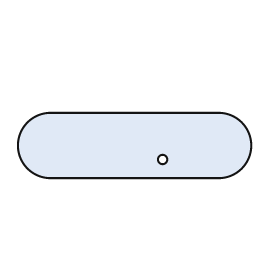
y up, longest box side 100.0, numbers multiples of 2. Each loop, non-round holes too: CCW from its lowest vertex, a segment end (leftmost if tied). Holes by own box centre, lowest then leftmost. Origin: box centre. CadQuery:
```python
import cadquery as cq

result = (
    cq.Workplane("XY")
    .moveTo(-36.0, -14.0)
    .lineTo(36.0, -14.0)
    .threePointArc((50.0, 0.0), (36.0, 14.0))
    .lineTo(-36.0, 14.0)
    .threePointArc((-50.0, 0.0), (-36.0, -14.0))
    .close()
    .moveTo(12.0, -6.0)
    .circle(2.0)
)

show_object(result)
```